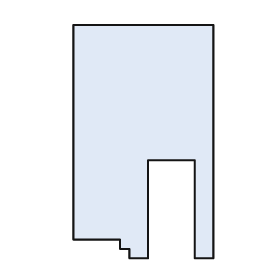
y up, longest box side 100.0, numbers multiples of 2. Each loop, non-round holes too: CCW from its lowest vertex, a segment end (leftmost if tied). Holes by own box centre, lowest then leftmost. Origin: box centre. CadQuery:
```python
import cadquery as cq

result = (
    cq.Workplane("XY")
    .moveTo(-6.0, -50.0)
    .lineTo(2.0, -50.0)
    .lineTo(2.0, -8.0)
    .lineTo(22.0, -8.0)
    .lineTo(22.0, -50.0)
    .lineTo(30.0, -50.0)
    .lineTo(30.0, 50.0)
    .lineTo(-30.0, 50.0)
    .lineTo(-30.0, -42.0)
    .lineTo(-10.0, -42.0)
    .lineTo(-10.0, -46.0)
    .lineTo(-6.0, -46.0)
    .close()
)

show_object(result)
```